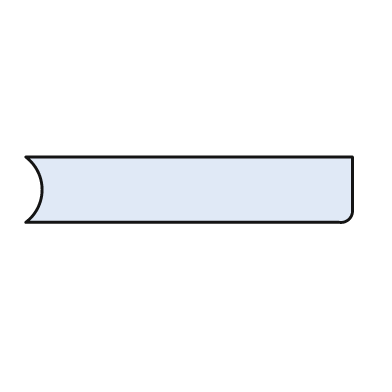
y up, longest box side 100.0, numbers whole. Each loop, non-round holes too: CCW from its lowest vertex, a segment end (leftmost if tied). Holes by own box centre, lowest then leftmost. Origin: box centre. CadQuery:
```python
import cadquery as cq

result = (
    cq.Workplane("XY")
    .moveTo(-50.0, -10.0)
    .lineTo(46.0, -10.0)
    .threePointArc((49.0, -9.0), (50.0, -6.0))
    .lineTo(50.0, 10.0)
    .lineTo(-50.0, 10.0)
    .threePointArc((-45.0, 0.0), (-50.0, -10.0))
    .close()
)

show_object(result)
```